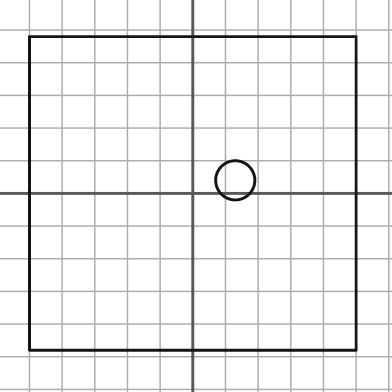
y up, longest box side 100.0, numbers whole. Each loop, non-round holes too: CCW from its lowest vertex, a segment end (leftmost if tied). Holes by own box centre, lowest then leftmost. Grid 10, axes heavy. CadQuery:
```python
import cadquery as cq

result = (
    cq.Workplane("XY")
    .moveTo(-50.0, -48.0)
    .lineTo(50.0, -48.0)
    .lineTo(50.0, 48.0)
    .lineTo(-50.0, 48.0)
    .close()
    .moveTo(13.0, 4.0)
    .circle(6.0)
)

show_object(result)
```